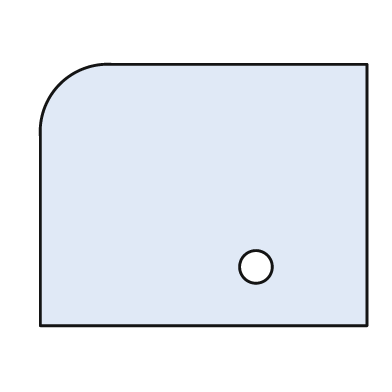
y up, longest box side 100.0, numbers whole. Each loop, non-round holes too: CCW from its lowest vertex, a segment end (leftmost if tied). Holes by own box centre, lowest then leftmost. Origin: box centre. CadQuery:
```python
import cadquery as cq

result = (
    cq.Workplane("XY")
    .moveTo(-50.0, -40.0)
    .lineTo(50.0, -40.0)
    .lineTo(50.0, 40.0)
    .lineTo(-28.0, 40.0)
    .threePointArc((-44.0, 34.0), (-50.0, 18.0))
    .close()
    .moveTo(16.0, -22.0)
    .circle(5.0)
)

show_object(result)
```